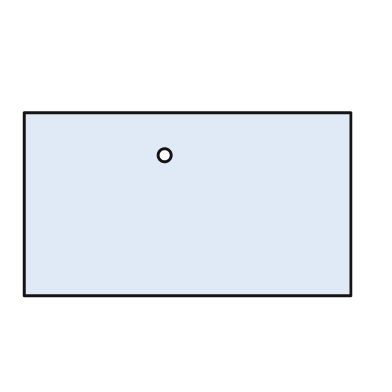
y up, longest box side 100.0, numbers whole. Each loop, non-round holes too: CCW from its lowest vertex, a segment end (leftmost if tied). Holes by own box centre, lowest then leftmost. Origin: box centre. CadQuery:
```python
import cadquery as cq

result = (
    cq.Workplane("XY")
    .moveTo(-50.0, -28.0)
    .lineTo(50.0, -28.0)
    .lineTo(50.0, 28.0)
    .lineTo(-50.0, 28.0)
    .close()
    .moveTo(-7.0, 15.0)
    .circle(2.0)
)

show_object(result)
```